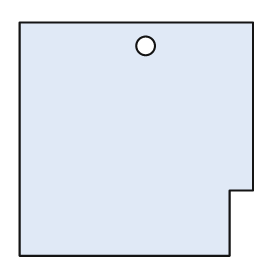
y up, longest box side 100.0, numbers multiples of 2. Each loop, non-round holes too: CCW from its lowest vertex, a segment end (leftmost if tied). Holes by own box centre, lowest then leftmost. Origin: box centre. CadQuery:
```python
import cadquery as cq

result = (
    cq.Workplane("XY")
    .moveTo(-50.0, -50.0)
    .lineTo(40.0, -50.0)
    .lineTo(40.0, -22.0)
    .lineTo(50.0, -22.0)
    .lineTo(50.0, 50.0)
    .lineTo(-50.0, 50.0)
    .close()
    .moveTo(4.0, 40.0)
    .circle(4.0)
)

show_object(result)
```